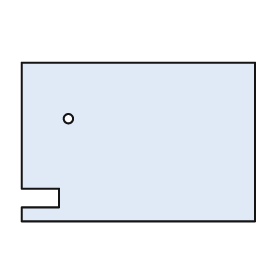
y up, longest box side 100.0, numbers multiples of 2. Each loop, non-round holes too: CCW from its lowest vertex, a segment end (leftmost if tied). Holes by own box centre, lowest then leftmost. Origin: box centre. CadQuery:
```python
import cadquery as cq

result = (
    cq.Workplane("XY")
    .moveTo(-50.0, -34.0)
    .lineTo(50.0, -34.0)
    .lineTo(50.0, 34.0)
    .lineTo(-50.0, 34.0)
    .lineTo(-50.0, -20.0)
    .lineTo(-34.0, -20.0)
    .lineTo(-34.0, -28.0)
    .lineTo(-50.0, -28.0)
    .close()
    .moveTo(-30.0, 10.0)
    .circle(2.0)
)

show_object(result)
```